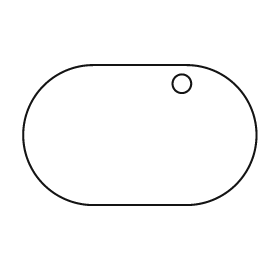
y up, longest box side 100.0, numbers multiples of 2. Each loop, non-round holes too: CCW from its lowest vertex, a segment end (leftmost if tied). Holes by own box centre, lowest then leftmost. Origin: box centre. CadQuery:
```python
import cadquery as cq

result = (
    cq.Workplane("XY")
    .moveTo(-20.0, -30.0)
    .lineTo(20.0, -30.0)
    .threePointArc((50.0, 0.0), (20.0, 30.0))
    .lineTo(-20.0, 30.0)
    .threePointArc((-50.0, 0.0), (-20.0, -30.0))
    .close()
    .moveTo(18.0, 22.0)
    .circle(4.0)
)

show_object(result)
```